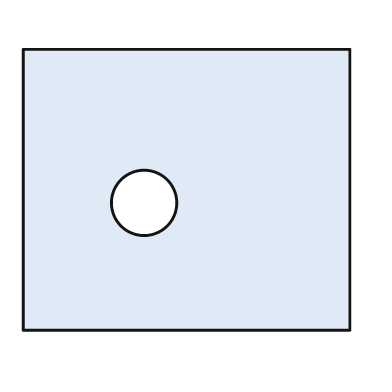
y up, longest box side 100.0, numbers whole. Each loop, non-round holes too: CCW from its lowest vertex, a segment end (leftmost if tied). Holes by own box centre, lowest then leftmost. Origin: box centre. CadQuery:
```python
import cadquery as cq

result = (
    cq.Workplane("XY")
    .moveTo(-50.0, -43.0)
    .lineTo(50.0, -43.0)
    .lineTo(50.0, 43.0)
    .lineTo(-50.0, 43.0)
    .close()
    .moveTo(-13.0, -4.0)
    .circle(10.0)
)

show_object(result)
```